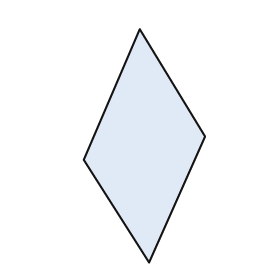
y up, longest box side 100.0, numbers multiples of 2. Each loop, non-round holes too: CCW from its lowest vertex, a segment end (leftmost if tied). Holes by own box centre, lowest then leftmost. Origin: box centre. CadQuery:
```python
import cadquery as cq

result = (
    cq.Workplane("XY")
    .moveTo(2.0, -50.0)
    .lineTo(26.0, 4.0)
    .lineTo(-2.0, 50.0)
    .lineTo(-26.0, -6.0)
    .close()
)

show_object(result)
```